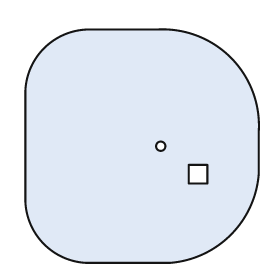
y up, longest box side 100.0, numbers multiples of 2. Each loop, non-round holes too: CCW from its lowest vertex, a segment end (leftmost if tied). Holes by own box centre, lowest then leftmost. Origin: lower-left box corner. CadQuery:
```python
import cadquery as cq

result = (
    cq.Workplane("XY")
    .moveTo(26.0, 0.0)
    .lineTo(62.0, 0.0)
    .threePointArc((88.0, 12.0), (100.0, 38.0))
    .lineTo(100.0, 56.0)
    .threePointArc((88.0, 88.0), (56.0, 100.0))
    .lineTo(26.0, 100.0)
    .threePointArc((8.0, 92.0), (0.0, 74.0))
    .lineTo(0.0, 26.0)
    .threePointArc((8.0, 8.0), (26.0, 0.0))
    .close()
    .moveTo(70.0, 34.0)
    .lineTo(78.0, 34.0)
    .lineTo(78.0, 42.0)
    .lineTo(70.0, 42.0)
    .close()
    .moveTo(58.0, 50.0)
    .circle(2.0)
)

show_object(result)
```